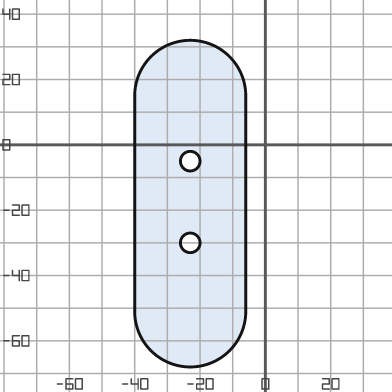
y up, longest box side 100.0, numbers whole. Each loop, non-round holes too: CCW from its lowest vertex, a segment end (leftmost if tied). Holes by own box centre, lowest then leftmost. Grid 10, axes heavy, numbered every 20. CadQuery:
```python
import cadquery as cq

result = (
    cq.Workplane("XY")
    .moveTo(-40.0, -51.0)
    .threePointArc((-23.0, -68.0), (-6.0, -51.0))
    .lineTo(-6.0, 15.0)
    .threePointArc((-23.0, 32.0), (-40.0, 15.0))
    .close()
    .moveTo(-23.0, -30.0)
    .circle(3.0)
    .moveTo(-23.0, -5.0)
    .circle(3.0)
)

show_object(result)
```